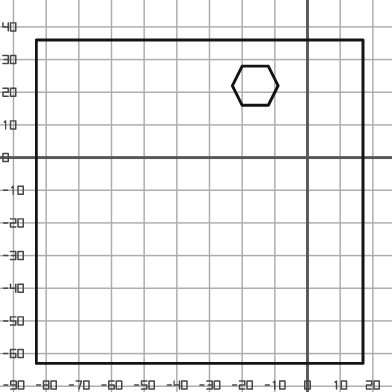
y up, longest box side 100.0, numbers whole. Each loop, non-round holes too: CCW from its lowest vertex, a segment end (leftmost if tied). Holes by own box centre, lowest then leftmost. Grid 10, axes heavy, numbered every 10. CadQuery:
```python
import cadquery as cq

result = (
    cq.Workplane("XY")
    .moveTo(-83.0, -63.0)
    .lineTo(17.0, -63.0)
    .lineTo(17.0, 36.0)
    .lineTo(-83.0, 36.0)
    .close()
    .moveTo(-20.0, 16.0)
    .lineTo(-12.0, 16.0)
    .lineTo(-9.0, 22.0)
    .lineTo(-12.0, 28.0)
    .lineTo(-20.0, 28.0)
    .lineTo(-23.0, 22.0)
    .close()
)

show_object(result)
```